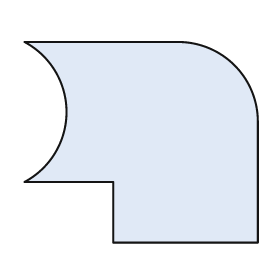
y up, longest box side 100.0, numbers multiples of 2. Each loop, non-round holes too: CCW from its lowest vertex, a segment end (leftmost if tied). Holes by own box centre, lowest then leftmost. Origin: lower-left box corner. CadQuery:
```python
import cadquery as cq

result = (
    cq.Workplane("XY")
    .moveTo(38.0, 0.0)
    .lineTo(100.0, 0.0)
    .lineTo(100.0, 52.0)
    .threePointArc((90.0, 76.0), (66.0, 86.0))
    .lineTo(0.0, 86.0)
    .threePointArc((18.0, 56.0), (0.0, 26.0))
    .lineTo(38.0, 26.0)
    .close()
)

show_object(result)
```